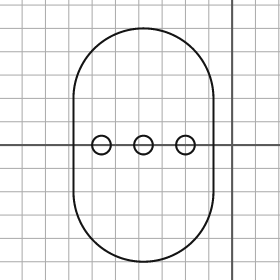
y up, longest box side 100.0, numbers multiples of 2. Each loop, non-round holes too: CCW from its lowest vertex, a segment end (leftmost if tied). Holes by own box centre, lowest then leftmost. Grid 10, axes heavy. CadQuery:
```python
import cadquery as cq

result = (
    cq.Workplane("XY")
    .moveTo(-68.0, -20.0)
    .threePointArc((-38.0, -50.0), (-8.0, -20.0))
    .lineTo(-8.0, 20.0)
    .threePointArc((-38.0, 50.0), (-68.0, 20.0))
    .close()
    .moveTo(-56.0, 0.0)
    .circle(4.0)
    .moveTo(-38.0, 0.0)
    .circle(4.0)
    .moveTo(-20.0, 0.0)
    .circle(4.0)
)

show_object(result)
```